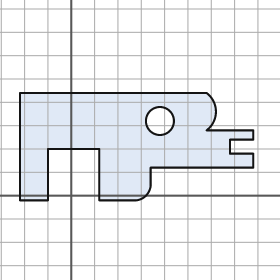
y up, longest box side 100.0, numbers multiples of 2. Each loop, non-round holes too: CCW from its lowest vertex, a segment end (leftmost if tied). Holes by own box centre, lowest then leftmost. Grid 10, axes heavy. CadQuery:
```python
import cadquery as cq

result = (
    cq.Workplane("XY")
    .moveTo(-22.0, -2.0)
    .lineTo(-10.0, -2.0)
    .lineTo(-10.0, 20.0)
    .lineTo(12.0, 20.0)
    .lineTo(12.0, -2.0)
    .lineTo(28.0, -2.0)
    .threePointArc((32.0, 0.0), (34.0, 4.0))
    .lineTo(34.0, 12.0)
    .lineTo(78.0, 12.0)
    .lineTo(78.0, 18.0)
    .lineTo(68.0, 18.0)
    .lineTo(68.0, 24.0)
    .lineTo(78.0, 24.0)
    .lineTo(78.0, 28.0)
    .lineTo(58.0, 28.0)
    .threePointArc((62.0, 36.0), (58.0, 44.0))
    .lineTo(-22.0, 44.0)
    .close()
    .moveTo(38.0, 32.0)
    .circle(6.0)
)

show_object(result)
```